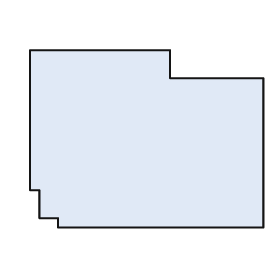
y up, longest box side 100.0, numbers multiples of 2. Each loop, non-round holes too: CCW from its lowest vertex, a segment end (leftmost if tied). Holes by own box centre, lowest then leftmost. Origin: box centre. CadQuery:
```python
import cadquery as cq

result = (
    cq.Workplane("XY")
    .moveTo(-38.0, -38.0)
    .lineTo(50.0, -38.0)
    .lineTo(50.0, 26.0)
    .lineTo(10.0, 26.0)
    .lineTo(10.0, 38.0)
    .lineTo(-50.0, 38.0)
    .lineTo(-50.0, -22.0)
    .lineTo(-46.0, -22.0)
    .lineTo(-46.0, -34.0)
    .lineTo(-38.0, -34.0)
    .close()
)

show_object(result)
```